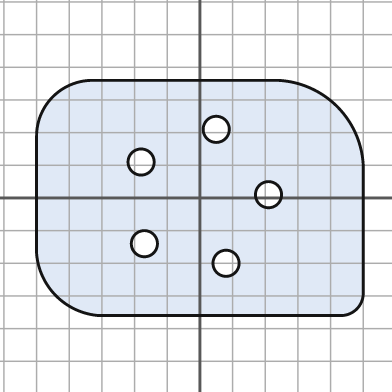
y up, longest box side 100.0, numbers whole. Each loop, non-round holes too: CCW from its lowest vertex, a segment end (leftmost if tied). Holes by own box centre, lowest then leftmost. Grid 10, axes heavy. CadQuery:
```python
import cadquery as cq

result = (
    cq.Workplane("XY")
    .moveTo(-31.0, -36.0)
    .lineTo(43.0, -36.0)
    .threePointArc((48.0, -34.0), (50.0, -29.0))
    .lineTo(50.0, 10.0)
    .threePointArc((42.0, 28.0), (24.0, 36.0))
    .lineTo(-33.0, 36.0)
    .threePointArc((-45.0, 31.0), (-50.0, 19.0))
    .lineTo(-50.0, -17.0)
    .threePointArc((-44.0, -30.0), (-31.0, -36.0))
    .close()
    .moveTo(8.0, -20.0)
    .circle(4.0)
    .moveTo(-17.0, -14.0)
    .circle(4.0)
    .moveTo(21.0, 1.0)
    .circle(4.0)
    .moveTo(-18.0, 11.0)
    .circle(4.0)
    .moveTo(5.0, 21.0)
    .circle(4.0)
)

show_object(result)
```